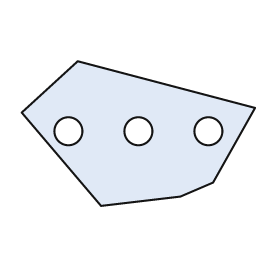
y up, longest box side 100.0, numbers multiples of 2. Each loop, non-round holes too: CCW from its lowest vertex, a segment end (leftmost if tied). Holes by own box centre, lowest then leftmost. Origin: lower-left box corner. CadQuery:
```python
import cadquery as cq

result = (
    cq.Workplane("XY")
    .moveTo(34.0, 0.0)
    .lineTo(68.0, 4.0)
    .lineTo(82.0, 10.0)
    .lineTo(100.0, 42.0)
    .lineTo(24.0, 62.0)
    .lineTo(0.0, 40.0)
    .close()
    .moveTo(20.0, 32.0)
    .circle(6.0)
    .moveTo(50.0, 32.0)
    .circle(6.0)
    .moveTo(80.0, 32.0)
    .circle(6.0)
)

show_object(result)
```